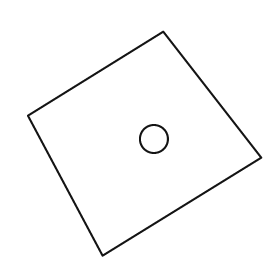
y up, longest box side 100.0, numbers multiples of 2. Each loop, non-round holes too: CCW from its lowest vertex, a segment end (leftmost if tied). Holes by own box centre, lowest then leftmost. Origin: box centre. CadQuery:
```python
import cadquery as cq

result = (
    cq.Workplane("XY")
    .moveTo(-18.0, -48.0)
    .lineTo(50.0, -6.0)
    .lineTo(8.0, 48.0)
    .lineTo(-50.0, 12.0)
    .close()
    .moveTo(4.0, 2.0)
    .circle(6.0)
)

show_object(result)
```